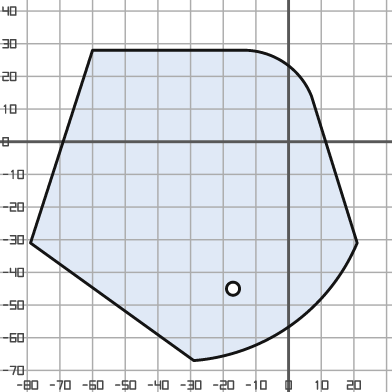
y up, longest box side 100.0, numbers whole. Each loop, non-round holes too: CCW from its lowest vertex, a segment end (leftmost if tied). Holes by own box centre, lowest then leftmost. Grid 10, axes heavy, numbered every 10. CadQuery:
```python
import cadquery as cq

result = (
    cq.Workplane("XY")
    .moveTo(-29.0, -67.0)
    .threePointArc((1.0, -56.0), (21.0, -31.0))
    .lineTo(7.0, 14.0)
    .threePointArc((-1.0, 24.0), (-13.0, 28.0))
    .lineTo(-60.0, 28.0)
    .lineTo(-79.0, -31.0)
    .close()
    .moveTo(-17.0, -45.0)
    .circle(2.0)
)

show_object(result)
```